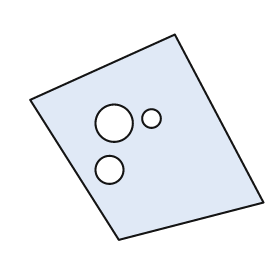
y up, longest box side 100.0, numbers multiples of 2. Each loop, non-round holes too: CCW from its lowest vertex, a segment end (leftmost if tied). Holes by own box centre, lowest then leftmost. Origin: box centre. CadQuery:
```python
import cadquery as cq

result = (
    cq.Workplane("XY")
    .moveTo(-12.0, -44.0)
    .lineTo(50.0, -28.0)
    .lineTo(12.0, 44.0)
    .lineTo(-50.0, 16.0)
    .close()
    .moveTo(-16.0, -14.0)
    .circle(6.0)
    .moveTo(-14.0, 6.0)
    .circle(8.0)
    .moveTo(2.0, 8.0)
    .circle(4.0)
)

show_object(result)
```